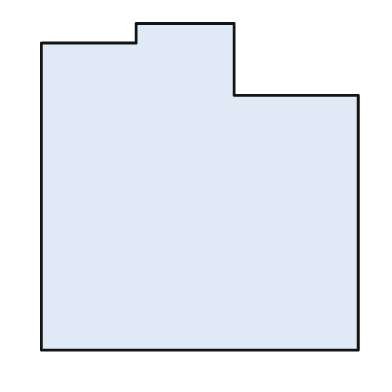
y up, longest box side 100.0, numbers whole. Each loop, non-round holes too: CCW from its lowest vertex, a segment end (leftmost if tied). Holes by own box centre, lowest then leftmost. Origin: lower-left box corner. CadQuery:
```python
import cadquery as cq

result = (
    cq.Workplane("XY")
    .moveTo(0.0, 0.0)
    .lineTo(97.0, 0.0)
    .lineTo(97.0, 78.0)
    .lineTo(59.0, 78.0)
    .lineTo(59.0, 100.0)
    .lineTo(29.0, 100.0)
    .lineTo(29.0, 94.0)
    .lineTo(0.0, 94.0)
    .close()
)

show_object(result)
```